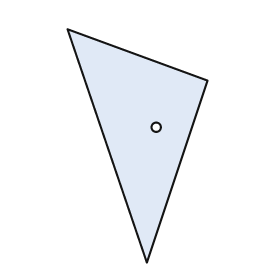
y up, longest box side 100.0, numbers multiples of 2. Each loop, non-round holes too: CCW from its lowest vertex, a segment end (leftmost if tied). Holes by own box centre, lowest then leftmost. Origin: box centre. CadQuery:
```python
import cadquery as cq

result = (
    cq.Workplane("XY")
    .moveTo(4.0, -50.0)
    .lineTo(30.0, 28.0)
    .lineTo(-30.0, 50.0)
    .close()
    .moveTo(8.0, 8.0)
    .circle(2.0)
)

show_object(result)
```